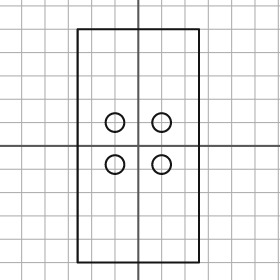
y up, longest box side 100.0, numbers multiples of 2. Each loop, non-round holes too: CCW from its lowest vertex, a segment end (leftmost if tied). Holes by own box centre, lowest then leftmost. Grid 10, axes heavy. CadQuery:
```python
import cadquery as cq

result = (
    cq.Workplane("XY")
    .moveTo(-26.0, -50.0)
    .lineTo(26.0, -50.0)
    .lineTo(26.0, 50.0)
    .lineTo(-26.0, 50.0)
    .close()
    .moveTo(-10.0, -8.0)
    .circle(4.0)
    .moveTo(10.0, -8.0)
    .circle(4.0)
    .moveTo(-10.0, 10.0)
    .circle(4.0)
    .moveTo(10.0, 10.0)
    .circle(4.0)
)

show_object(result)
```